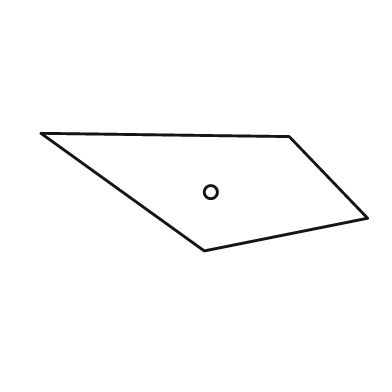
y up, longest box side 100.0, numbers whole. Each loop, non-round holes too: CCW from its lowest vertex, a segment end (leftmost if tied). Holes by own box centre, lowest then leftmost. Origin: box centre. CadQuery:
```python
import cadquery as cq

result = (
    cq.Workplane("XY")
    .moveTo(0.0, -18.0)
    .lineTo(50.0, -8.0)
    .lineTo(26.0, 17.0)
    .lineTo(-50.0, 18.0)
    .close()
    .moveTo(2.0, 0.0)
    .circle(2.0)
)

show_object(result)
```